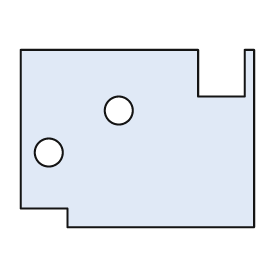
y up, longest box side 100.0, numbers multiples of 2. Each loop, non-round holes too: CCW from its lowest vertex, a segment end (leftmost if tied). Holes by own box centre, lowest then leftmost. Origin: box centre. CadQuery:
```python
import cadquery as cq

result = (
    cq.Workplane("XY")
    .moveTo(-30.0, -38.0)
    .lineTo(50.0, -38.0)
    .lineTo(50.0, 38.0)
    .lineTo(46.0, 38.0)
    .lineTo(46.0, 18.0)
    .lineTo(26.0, 18.0)
    .lineTo(26.0, 38.0)
    .lineTo(-50.0, 38.0)
    .lineTo(-50.0, -30.0)
    .lineTo(-30.0, -30.0)
    .close()
    .moveTo(-38.0, -6.0)
    .circle(6.0)
    .moveTo(-8.0, 12.0)
    .circle(6.0)
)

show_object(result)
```